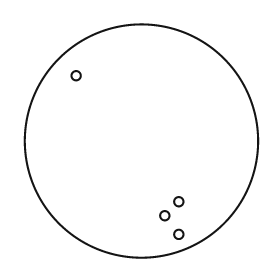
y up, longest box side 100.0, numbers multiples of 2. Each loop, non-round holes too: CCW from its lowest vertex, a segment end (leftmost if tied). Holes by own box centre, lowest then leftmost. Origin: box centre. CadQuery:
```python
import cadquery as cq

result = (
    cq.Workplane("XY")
    .moveTo(0.0, 0.0)
    .circle(50.0)
    .moveTo(16.0, -40.0)
    .circle(2.0)
    .moveTo(10.0, -32.0)
    .circle(2.0)
    .moveTo(16.0, -26.0)
    .circle(2.0)
    .moveTo(-28.0, 28.0)
    .circle(2.0)
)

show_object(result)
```